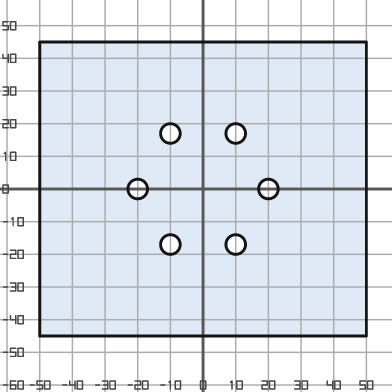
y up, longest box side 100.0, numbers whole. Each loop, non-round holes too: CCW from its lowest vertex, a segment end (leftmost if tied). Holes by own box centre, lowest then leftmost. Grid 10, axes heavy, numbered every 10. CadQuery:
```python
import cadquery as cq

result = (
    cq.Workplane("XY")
    .moveTo(-50.0, -45.0)
    .lineTo(50.0, -45.0)
    .lineTo(50.0, 45.0)
    .lineTo(-50.0, 45.0)
    .close()
    .moveTo(-10.0, -17.0)
    .circle(3.0)
    .moveTo(10.0, -17.0)
    .circle(3.0)
    .moveTo(-20.0, 0.0)
    .circle(3.0)
    .moveTo(20.0, 0.0)
    .circle(3.0)
    .moveTo(-10.0, 17.0)
    .circle(3.0)
    .moveTo(10.0, 17.0)
    .circle(3.0)
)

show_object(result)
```